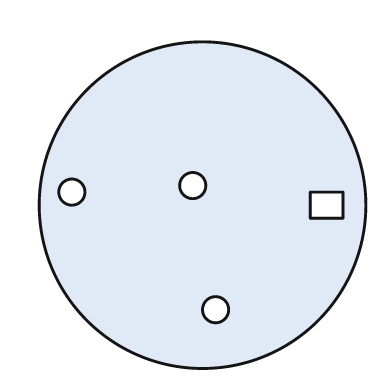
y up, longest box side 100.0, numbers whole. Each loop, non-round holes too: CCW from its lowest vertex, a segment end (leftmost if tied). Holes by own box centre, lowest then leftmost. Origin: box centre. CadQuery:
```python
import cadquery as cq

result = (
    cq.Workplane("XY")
    .moveTo(0.0, 0.0)
    .circle(50.0)
    .moveTo(4.0, -32.0)
    .circle(4.0)
    .moveTo(33.0, -4.0)
    .lineTo(43.0, -4.0)
    .lineTo(43.0, 4.0)
    .lineTo(33.0, 4.0)
    .close()
    .moveTo(-40.0, 4.0)
    .circle(4.0)
    .moveTo(-3.0, 6.0)
    .circle(4.0)
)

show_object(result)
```